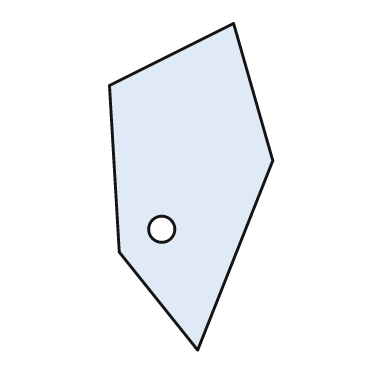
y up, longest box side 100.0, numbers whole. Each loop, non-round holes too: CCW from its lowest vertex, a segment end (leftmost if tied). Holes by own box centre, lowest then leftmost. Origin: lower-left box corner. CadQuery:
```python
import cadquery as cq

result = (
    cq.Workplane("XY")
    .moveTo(27.0, 0.0)
    .lineTo(50.0, 58.0)
    .lineTo(38.0, 100.0)
    .lineTo(0.0, 81.0)
    .lineTo(3.0, 30.0)
    .close()
    .moveTo(16.0, 37.0)
    .circle(4.0)
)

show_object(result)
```